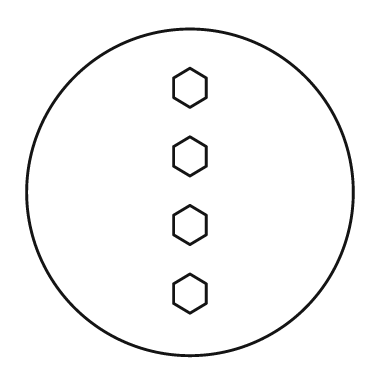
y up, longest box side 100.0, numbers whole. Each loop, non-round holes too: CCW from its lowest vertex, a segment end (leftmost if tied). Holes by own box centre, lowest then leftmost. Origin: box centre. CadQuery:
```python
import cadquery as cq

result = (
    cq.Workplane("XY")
    .moveTo(0.0, 0.0)
    .circle(50.0)
    .moveTo(0.0, -37.0)
    .lineTo(5.0, -34.0)
    .lineTo(5.0, -28.0)
    .lineTo(0.0, -25.0)
    .lineTo(-5.0, -28.0)
    .lineTo(-5.0, -34.0)
    .close()
    .moveTo(0.0, -16.0)
    .lineTo(5.0, -13.0)
    .lineTo(5.0, -7.0)
    .lineTo(0.0, -4.0)
    .lineTo(-5.0, -7.0)
    .lineTo(-5.0, -13.0)
    .close()
    .moveTo(0.0, 5.0)
    .lineTo(5.0, 8.0)
    .lineTo(5.0, 14.0)
    .lineTo(0.0, 17.0)
    .lineTo(-5.0, 14.0)
    .lineTo(-5.0, 8.0)
    .close()
    .moveTo(0.0, 26.0)
    .lineTo(5.0, 29.0)
    .lineTo(5.0, 35.0)
    .lineTo(0.0, 38.0)
    .lineTo(-5.0, 35.0)
    .lineTo(-5.0, 29.0)
    .close()
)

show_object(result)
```